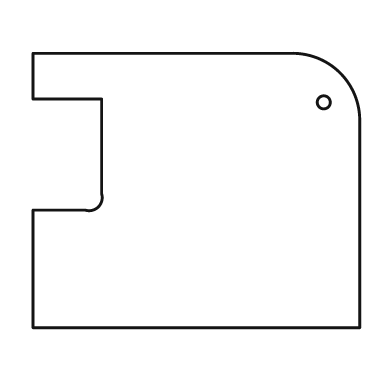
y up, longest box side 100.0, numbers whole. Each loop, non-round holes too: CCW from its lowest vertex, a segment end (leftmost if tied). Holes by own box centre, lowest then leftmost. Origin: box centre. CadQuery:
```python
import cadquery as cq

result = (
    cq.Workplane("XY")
    .moveTo(-50.0, -42.0)
    .lineTo(50.0, -42.0)
    .lineTo(50.0, 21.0)
    .threePointArc((44.0, 36.0), (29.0, 42.0))
    .lineTo(-50.0, 42.0)
    .lineTo(-50.0, 28.0)
    .lineTo(-29.0, 28.0)
    .lineTo(-29.0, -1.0)
    .threePointArc((-30.0, -5.0), (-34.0, -6.0))
    .lineTo(-50.0, -6.0)
    .close()
    .moveTo(39.0, 27.0)
    .circle(2.0)
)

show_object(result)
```